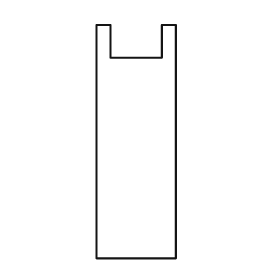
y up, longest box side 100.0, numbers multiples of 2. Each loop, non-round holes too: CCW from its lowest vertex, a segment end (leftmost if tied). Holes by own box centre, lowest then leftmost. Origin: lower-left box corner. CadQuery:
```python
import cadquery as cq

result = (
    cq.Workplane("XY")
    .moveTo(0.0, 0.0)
    .lineTo(34.0, 0.0)
    .lineTo(34.0, 100.0)
    .lineTo(28.0, 100.0)
    .lineTo(28.0, 86.0)
    .lineTo(6.0, 86.0)
    .lineTo(6.0, 100.0)
    .lineTo(0.0, 100.0)
    .close()
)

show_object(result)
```